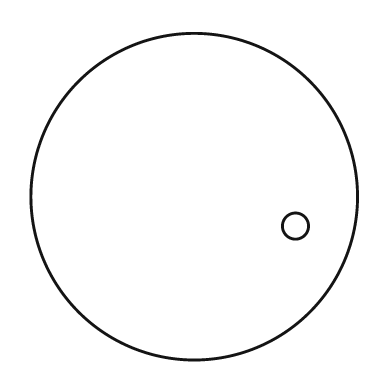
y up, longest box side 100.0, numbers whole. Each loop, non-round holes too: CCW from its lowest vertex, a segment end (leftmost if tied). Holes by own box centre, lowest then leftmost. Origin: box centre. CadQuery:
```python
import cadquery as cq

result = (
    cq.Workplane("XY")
    .moveTo(0.0, 0.0)
    .circle(50.0)
    .moveTo(31.0, -9.0)
    .circle(4.0)
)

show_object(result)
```